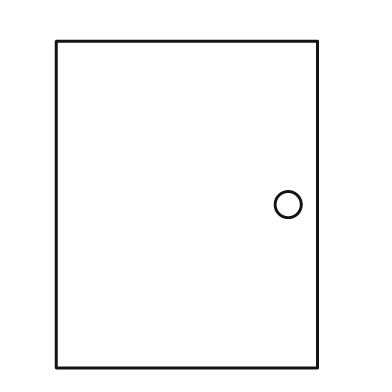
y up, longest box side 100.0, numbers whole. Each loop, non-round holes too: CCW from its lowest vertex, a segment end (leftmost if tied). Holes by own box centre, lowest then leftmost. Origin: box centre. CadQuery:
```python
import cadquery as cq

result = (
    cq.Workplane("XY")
    .moveTo(-40.0, -50.0)
    .lineTo(40.0, -50.0)
    .lineTo(40.0, 50.0)
    .lineTo(-40.0, 50.0)
    .close()
    .moveTo(31.0, 0.0)
    .circle(4.0)
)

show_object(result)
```